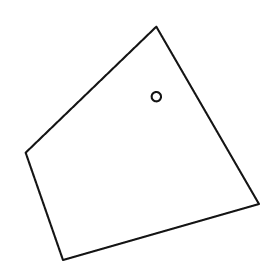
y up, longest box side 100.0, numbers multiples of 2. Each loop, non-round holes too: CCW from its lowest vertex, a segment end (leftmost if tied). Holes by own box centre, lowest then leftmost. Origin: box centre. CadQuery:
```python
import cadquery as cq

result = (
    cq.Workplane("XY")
    .moveTo(-34.0, -50.0)
    .lineTo(50.0, -26.0)
    .lineTo(6.0, 50.0)
    .lineTo(-50.0, -4.0)
    .close()
    .moveTo(6.0, 20.0)
    .circle(2.0)
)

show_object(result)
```